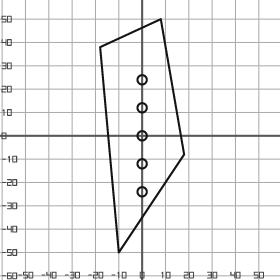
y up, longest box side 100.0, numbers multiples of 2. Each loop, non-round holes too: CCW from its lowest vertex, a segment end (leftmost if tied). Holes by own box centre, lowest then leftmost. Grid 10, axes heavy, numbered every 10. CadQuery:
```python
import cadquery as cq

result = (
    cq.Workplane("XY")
    .moveTo(-10.0, -50.0)
    .lineTo(18.0, -8.0)
    .lineTo(8.0, 50.0)
    .lineTo(-18.0, 38.0)
    .close()
    .moveTo(0.0, -24.0)
    .circle(2.0)
    .moveTo(0.0, -12.0)
    .circle(2.0)
    .moveTo(0.0, 0.0)
    .circle(2.0)
    .moveTo(0.0, 12.0)
    .circle(2.0)
    .moveTo(0.0, 24.0)
    .circle(2.0)
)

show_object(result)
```